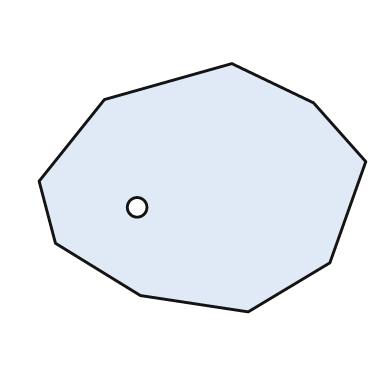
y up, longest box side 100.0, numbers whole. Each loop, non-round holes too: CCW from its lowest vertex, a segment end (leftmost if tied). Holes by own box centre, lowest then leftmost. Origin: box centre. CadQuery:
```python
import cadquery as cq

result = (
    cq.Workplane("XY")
    .moveTo(14.0, -38.0)
    .lineTo(39.0, -23.0)
    .lineTo(50.0, 8.0)
    .lineTo(34.0, 26.0)
    .lineTo(9.0, 38.0)
    .lineTo(-30.0, 27.0)
    .lineTo(-50.0, 2.0)
    .lineTo(-45.0, -17.0)
    .lineTo(-19.0, -33.0)
    .close()
    .moveTo(-20.0, -6.0)
    .circle(3.0)
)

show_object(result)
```